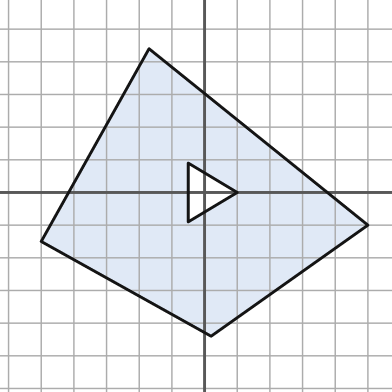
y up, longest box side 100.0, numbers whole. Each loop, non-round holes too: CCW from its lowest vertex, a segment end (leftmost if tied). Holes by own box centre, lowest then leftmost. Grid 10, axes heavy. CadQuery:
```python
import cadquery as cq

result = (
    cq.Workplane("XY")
    .moveTo(2.0, -44.0)
    .lineTo(50.0, -10.0)
    .lineTo(-17.0, 44.0)
    .lineTo(-50.0, -15.0)
    .close()
    .moveTo(-5.0, -9.0)
    .lineTo(10.0, 0.0)
    .lineTo(-5.0, 9.0)
    .close()
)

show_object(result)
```